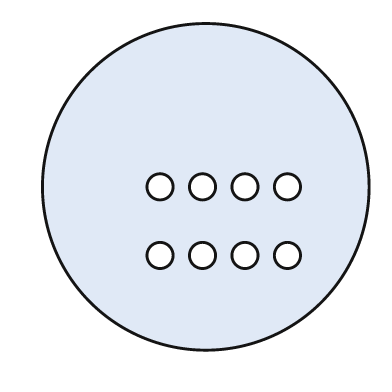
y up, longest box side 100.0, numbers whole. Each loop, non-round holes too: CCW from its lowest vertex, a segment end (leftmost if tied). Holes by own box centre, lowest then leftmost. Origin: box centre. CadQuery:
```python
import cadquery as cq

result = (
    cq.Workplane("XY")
    .moveTo(0.0, 0.0)
    .circle(50.0)
    .moveTo(-14.0, -21.0)
    .circle(4.0)
    .moveTo(-1.0, -21.0)
    .circle(4.0)
    .moveTo(12.0, -21.0)
    .circle(4.0)
    .moveTo(25.0, -21.0)
    .circle(4.0)
    .moveTo(-14.0, 0.0)
    .circle(4.0)
    .moveTo(-1.0, 0.0)
    .circle(4.0)
    .moveTo(12.0, 0.0)
    .circle(4.0)
    .moveTo(25.0, 0.0)
    .circle(4.0)
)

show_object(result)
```